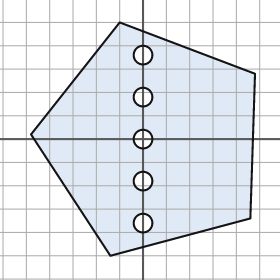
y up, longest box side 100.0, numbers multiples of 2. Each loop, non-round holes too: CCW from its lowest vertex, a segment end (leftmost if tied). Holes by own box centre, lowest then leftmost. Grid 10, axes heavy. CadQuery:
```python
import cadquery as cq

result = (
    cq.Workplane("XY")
    .moveTo(-14.0, -50.0)
    .lineTo(46.0, -34.0)
    .lineTo(48.0, 28.0)
    .lineTo(-10.0, 50.0)
    .lineTo(-48.0, 2.0)
    .close()
    .moveTo(0.0, -36.0)
    .circle(4.0)
    .moveTo(0.0, -18.0)
    .circle(4.0)
    .moveTo(0.0, 0.0)
    .circle(4.0)
    .moveTo(0.0, 18.0)
    .circle(4.0)
    .moveTo(0.0, 36.0)
    .circle(4.0)
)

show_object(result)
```